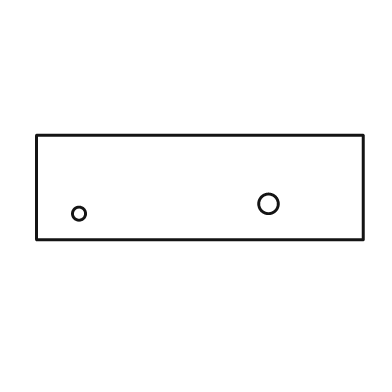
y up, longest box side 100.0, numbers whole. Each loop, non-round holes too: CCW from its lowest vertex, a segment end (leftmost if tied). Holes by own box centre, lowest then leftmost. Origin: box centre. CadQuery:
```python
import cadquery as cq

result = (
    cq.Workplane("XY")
    .moveTo(-50.0, -16.0)
    .lineTo(50.0, -16.0)
    .lineTo(50.0, 16.0)
    .lineTo(-50.0, 16.0)
    .close()
    .moveTo(-37.0, -8.0)
    .circle(2.0)
    .moveTo(21.0, -5.0)
    .circle(3.0)
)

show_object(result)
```